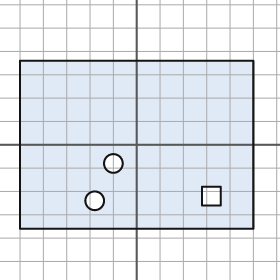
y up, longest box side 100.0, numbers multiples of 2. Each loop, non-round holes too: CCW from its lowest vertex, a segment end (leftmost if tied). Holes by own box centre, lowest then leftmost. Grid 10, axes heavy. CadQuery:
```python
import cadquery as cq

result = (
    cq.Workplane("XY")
    .moveTo(-50.0, -36.0)
    .lineTo(50.0, -36.0)
    .lineTo(50.0, 36.0)
    .lineTo(-50.0, 36.0)
    .close()
    .moveTo(-18.0, -24.0)
    .circle(4.0)
    .moveTo(28.0, -26.0)
    .lineTo(36.0, -26.0)
    .lineTo(36.0, -18.0)
    .lineTo(28.0, -18.0)
    .close()
    .moveTo(-10.0, -8.0)
    .circle(4.0)
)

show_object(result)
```